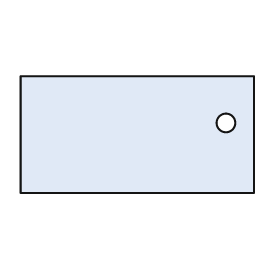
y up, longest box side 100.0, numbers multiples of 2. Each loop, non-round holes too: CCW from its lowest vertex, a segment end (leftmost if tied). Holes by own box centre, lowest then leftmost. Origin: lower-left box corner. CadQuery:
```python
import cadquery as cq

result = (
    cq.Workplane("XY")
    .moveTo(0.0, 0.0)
    .lineTo(100.0, 0.0)
    .lineTo(100.0, 50.0)
    .lineTo(0.0, 50.0)
    .close()
    .moveTo(88.0, 30.0)
    .circle(4.0)
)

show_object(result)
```